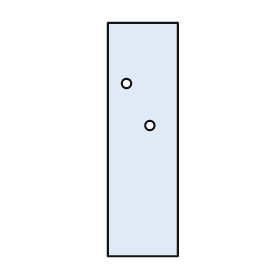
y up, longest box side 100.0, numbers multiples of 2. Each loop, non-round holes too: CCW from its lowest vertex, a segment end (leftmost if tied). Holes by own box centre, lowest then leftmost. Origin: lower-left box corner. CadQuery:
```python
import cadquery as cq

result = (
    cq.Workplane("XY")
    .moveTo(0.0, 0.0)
    .lineTo(30.0, 0.0)
    .lineTo(30.0, 100.0)
    .lineTo(0.0, 100.0)
    .close()
    .moveTo(18.0, 56.0)
    .circle(2.0)
    .moveTo(8.0, 74.0)
    .circle(2.0)
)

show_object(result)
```